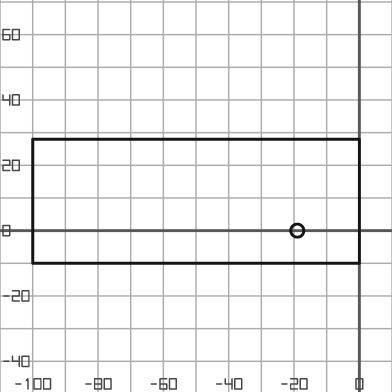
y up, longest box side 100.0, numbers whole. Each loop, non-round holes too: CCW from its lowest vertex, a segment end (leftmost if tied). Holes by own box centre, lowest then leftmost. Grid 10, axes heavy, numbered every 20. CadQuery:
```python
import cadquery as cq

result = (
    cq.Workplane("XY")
    .moveTo(-100.0, -10.0)
    .lineTo(0.0, -10.0)
    .lineTo(0.0, 28.0)
    .lineTo(-100.0, 28.0)
    .close()
    .moveTo(-19.0, 0.0)
    .circle(2.0)
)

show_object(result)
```